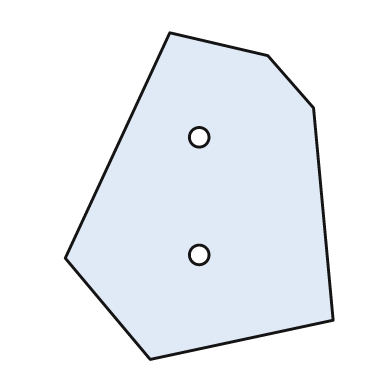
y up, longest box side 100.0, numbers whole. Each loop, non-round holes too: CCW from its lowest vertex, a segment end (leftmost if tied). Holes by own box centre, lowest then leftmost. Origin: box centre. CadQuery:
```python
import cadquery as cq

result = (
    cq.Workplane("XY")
    .moveTo(-15.0, -50.0)
    .lineTo(41.0, -38.0)
    .lineTo(35.0, 27.0)
    .lineTo(21.0, 43.0)
    .lineTo(-9.0, 50.0)
    .lineTo(-41.0, -19.0)
    .close()
    .moveTo(0.0, -18.0)
    .circle(3.0)
    .moveTo(0.0, 18.0)
    .circle(3.0)
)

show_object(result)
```